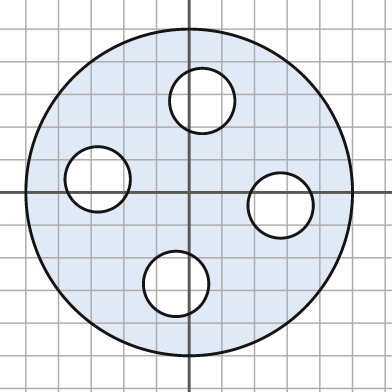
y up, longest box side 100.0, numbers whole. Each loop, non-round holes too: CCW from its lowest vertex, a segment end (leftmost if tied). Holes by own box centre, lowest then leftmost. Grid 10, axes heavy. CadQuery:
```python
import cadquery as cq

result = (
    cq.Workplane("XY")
    .moveTo(0.0, 0.0)
    .circle(50.0)
    .moveTo(-4.0, -28.0)
    .circle(10.0)
    .moveTo(28.0, -4.0)
    .circle(10.0)
    .moveTo(-28.0, 4.0)
    .circle(10.0)
    .moveTo(4.0, 28.0)
    .circle(10.0)
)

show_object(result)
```